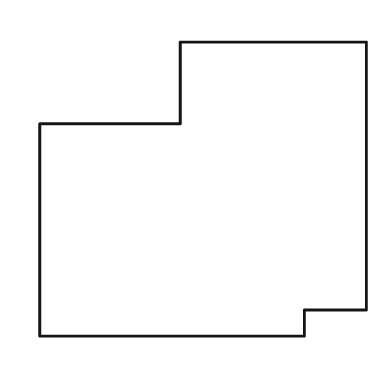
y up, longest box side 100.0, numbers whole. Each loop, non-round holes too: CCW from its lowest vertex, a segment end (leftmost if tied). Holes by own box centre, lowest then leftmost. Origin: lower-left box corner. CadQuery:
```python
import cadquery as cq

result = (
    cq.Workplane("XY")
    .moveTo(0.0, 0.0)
    .lineTo(81.0, 0.0)
    .lineTo(81.0, 8.0)
    .lineTo(100.0, 8.0)
    .lineTo(100.0, 90.0)
    .lineTo(43.0, 90.0)
    .lineTo(43.0, 65.0)
    .lineTo(0.0, 65.0)
    .close()
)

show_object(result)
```